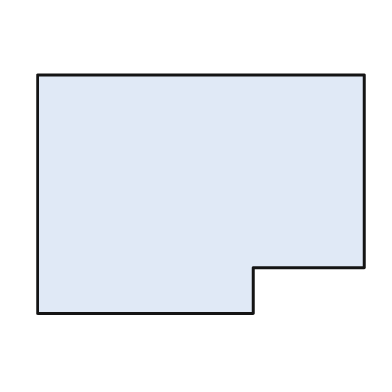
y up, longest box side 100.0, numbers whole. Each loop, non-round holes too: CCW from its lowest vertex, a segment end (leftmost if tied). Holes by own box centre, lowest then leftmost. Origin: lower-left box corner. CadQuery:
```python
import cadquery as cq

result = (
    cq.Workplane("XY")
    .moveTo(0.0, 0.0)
    .lineTo(66.0, 0.0)
    .lineTo(66.0, 14.0)
    .lineTo(100.0, 14.0)
    .lineTo(100.0, 73.0)
    .lineTo(0.0, 73.0)
    .close()
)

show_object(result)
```